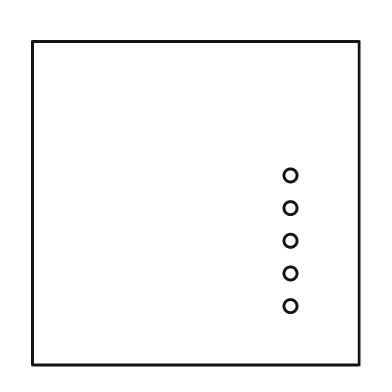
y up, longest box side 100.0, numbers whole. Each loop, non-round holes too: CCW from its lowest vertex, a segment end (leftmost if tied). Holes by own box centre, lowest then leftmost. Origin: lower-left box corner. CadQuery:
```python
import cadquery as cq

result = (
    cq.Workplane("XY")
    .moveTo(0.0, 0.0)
    .lineTo(100.0, 0.0)
    .lineTo(100.0, 99.0)
    .lineTo(0.0, 99.0)
    .close()
    .moveTo(79.0, 18.0)
    .circle(2.0)
    .moveTo(79.0, 28.0)
    .circle(2.0)
    .moveTo(79.0, 38.0)
    .circle(2.0)
    .moveTo(79.0, 48.0)
    .circle(2.0)
    .moveTo(79.0, 58.0)
    .circle(2.0)
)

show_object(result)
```